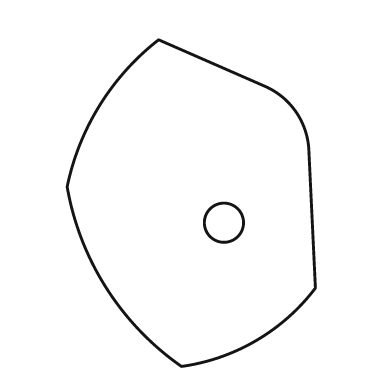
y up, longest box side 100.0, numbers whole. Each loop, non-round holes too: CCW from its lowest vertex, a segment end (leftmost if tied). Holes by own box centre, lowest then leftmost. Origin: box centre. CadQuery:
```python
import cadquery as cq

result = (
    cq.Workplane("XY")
    .moveTo(-3.0, -50.0)
    .threePointArc((20.0, -42.0), (38.0, -26.0))
    .lineTo(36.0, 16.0)
    .threePointArc((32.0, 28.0), (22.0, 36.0))
    .lineTo(-10.0, 50.0)
    .threePointArc((-28.0, 30.0), (-38.0, 5.0))
    .threePointArc((-26.0, -26.0), (-3.0, -50.0))
    .close()
    .moveTo(10.0, -6.0)
    .circle(6.0)
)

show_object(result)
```